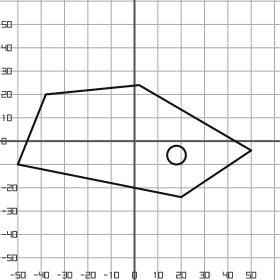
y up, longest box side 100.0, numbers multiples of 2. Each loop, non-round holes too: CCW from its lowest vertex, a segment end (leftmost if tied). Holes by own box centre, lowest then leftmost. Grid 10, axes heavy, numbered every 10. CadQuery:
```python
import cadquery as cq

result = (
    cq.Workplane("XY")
    .moveTo(20.0, -24.0)
    .lineTo(50.0, -4.0)
    .lineTo(2.0, 24.0)
    .lineTo(-38.0, 20.0)
    .lineTo(-50.0, -10.0)
    .close()
    .moveTo(18.0, -6.0)
    .circle(4.0)
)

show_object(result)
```